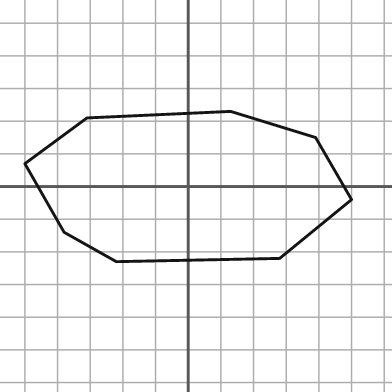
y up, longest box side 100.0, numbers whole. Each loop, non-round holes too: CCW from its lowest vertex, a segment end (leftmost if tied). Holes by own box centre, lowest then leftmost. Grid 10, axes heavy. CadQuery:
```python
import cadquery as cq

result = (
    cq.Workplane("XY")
    .moveTo(-22.0, -23.0)
    .lineTo(28.0, -22.0)
    .lineTo(50.0, -4.0)
    .lineTo(39.0, 15.0)
    .lineTo(13.0, 23.0)
    .lineTo(-31.0, 21.0)
    .lineTo(-50.0, 7.0)
    .lineTo(-38.0, -14.0)
    .close()
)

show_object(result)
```